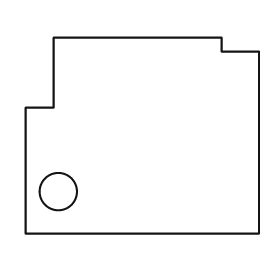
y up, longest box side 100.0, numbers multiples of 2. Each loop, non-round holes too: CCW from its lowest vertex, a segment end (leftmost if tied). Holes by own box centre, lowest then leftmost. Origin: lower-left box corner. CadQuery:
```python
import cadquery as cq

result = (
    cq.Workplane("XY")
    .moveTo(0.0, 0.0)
    .lineTo(100.0, 0.0)
    .lineTo(100.0, 78.0)
    .lineTo(84.0, 78.0)
    .lineTo(84.0, 84.0)
    .lineTo(12.0, 84.0)
    .lineTo(12.0, 54.0)
    .lineTo(0.0, 54.0)
    .close()
    .moveTo(14.0, 18.0)
    .circle(8.0)
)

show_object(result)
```